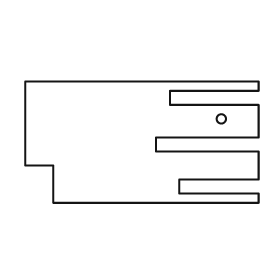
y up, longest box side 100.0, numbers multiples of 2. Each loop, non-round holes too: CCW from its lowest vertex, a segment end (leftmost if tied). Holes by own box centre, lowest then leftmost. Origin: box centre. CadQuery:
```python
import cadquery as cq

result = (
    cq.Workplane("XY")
    .moveTo(-38.0, -26.0)
    .lineTo(50.0, -26.0)
    .lineTo(50.0, -22.0)
    .lineTo(16.0, -22.0)
    .lineTo(16.0, -16.0)
    .lineTo(50.0, -16.0)
    .lineTo(50.0, -4.0)
    .lineTo(6.0, -4.0)
    .lineTo(6.0, 2.0)
    .lineTo(50.0, 2.0)
    .lineTo(50.0, 16.0)
    .lineTo(12.0, 16.0)
    .lineTo(12.0, 22.0)
    .lineTo(50.0, 22.0)
    .lineTo(50.0, 26.0)
    .lineTo(-50.0, 26.0)
    .lineTo(-50.0, -10.0)
    .lineTo(-38.0, -10.0)
    .close()
    .moveTo(34.0, 10.0)
    .circle(2.0)
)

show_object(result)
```